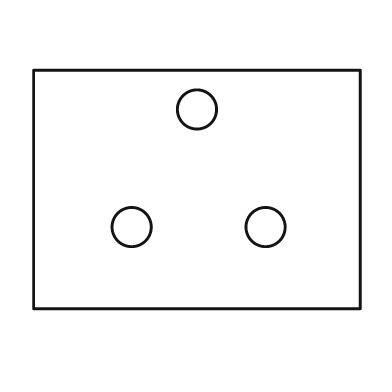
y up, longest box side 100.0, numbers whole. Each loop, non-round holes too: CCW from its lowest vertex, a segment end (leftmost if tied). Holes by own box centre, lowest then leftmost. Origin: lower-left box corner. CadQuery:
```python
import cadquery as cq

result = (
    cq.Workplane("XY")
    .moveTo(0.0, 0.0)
    .lineTo(100.0, 0.0)
    .lineTo(100.0, 73.0)
    .lineTo(0.0, 73.0)
    .close()
    .moveTo(30.0, 25.0)
    .circle(6.0)
    .moveTo(71.0, 25.0)
    .circle(6.0)
    .moveTo(50.0, 61.0)
    .circle(6.0)
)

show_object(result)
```